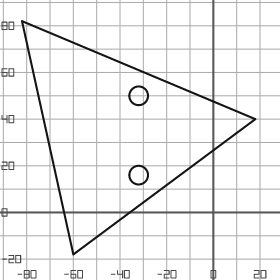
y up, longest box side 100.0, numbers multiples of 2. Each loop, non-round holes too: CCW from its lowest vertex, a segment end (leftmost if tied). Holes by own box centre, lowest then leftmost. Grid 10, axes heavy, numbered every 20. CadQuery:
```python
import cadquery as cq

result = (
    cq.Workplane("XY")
    .moveTo(-60.0, -18.0)
    .lineTo(18.0, 40.0)
    .lineTo(-82.0, 82.0)
    .close()
    .moveTo(-32.0, 16.0)
    .circle(4.0)
    .moveTo(-32.0, 50.0)
    .circle(4.0)
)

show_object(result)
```